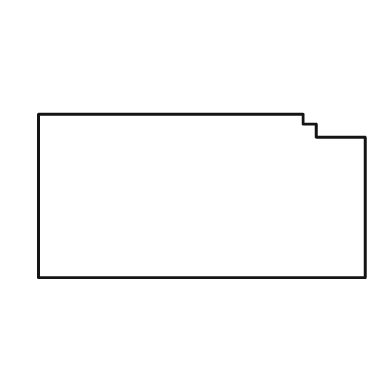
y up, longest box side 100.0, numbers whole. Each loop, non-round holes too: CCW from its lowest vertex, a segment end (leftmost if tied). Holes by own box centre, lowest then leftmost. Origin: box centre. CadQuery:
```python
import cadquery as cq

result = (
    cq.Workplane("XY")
    .moveTo(-50.0, -25.0)
    .lineTo(50.0, -25.0)
    .lineTo(50.0, 18.0)
    .lineTo(35.0, 18.0)
    .lineTo(35.0, 22.0)
    .lineTo(31.0, 22.0)
    .lineTo(31.0, 25.0)
    .lineTo(-50.0, 25.0)
    .close()
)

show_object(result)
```